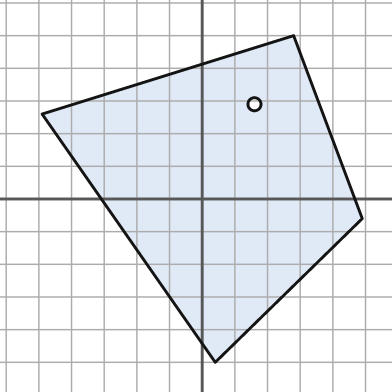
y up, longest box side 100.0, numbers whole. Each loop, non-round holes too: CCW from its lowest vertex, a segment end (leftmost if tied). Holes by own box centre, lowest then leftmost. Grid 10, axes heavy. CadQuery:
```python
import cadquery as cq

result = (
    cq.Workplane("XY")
    .moveTo(4.0, -50.0)
    .lineTo(49.0, -6.0)
    .lineTo(28.0, 50.0)
    .lineTo(-49.0, 26.0)
    .close()
    .moveTo(16.0, 29.0)
    .circle(2.0)
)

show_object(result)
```